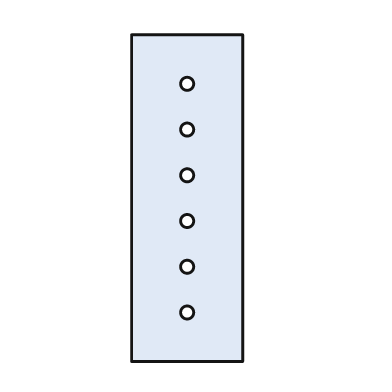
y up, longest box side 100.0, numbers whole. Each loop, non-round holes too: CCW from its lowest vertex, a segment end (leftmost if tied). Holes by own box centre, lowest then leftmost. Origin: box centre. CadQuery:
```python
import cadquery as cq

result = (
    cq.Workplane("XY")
    .moveTo(-17.0, -50.0)
    .lineTo(17.0, -50.0)
    .lineTo(17.0, 50.0)
    .lineTo(-17.0, 50.0)
    .close()
    .moveTo(0.0, -35.0)
    .circle(2.0)
    .moveTo(0.0, -21.0)
    .circle(2.0)
    .moveTo(0.0, -7.0)
    .circle(2.0)
    .moveTo(0.0, 7.0)
    .circle(2.0)
    .moveTo(0.0, 21.0)
    .circle(2.0)
    .moveTo(0.0, 35.0)
    .circle(2.0)
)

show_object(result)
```